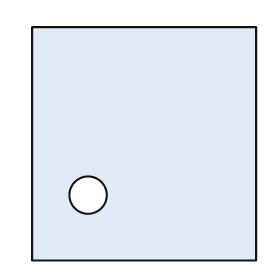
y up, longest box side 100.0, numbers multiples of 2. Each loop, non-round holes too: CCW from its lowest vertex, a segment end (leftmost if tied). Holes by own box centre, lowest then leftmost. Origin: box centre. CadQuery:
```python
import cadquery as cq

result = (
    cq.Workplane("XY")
    .moveTo(-48.0, -50.0)
    .lineTo(48.0, -50.0)
    .lineTo(48.0, 50.0)
    .lineTo(-48.0, 50.0)
    .close()
    .moveTo(-24.0, -22.0)
    .circle(8.0)
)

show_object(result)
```